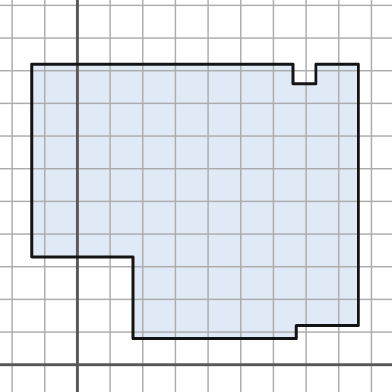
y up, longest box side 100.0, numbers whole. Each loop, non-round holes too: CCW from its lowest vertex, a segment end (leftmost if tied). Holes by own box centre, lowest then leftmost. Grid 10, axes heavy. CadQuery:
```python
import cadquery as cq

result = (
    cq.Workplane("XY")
    .moveTo(17.0, 8.0)
    .lineTo(67.0, 8.0)
    .lineTo(67.0, 12.0)
    .lineTo(86.0, 12.0)
    .lineTo(86.0, 92.0)
    .lineTo(73.0, 92.0)
    .lineTo(73.0, 86.0)
    .lineTo(66.0, 86.0)
    .lineTo(66.0, 92.0)
    .lineTo(-14.0, 92.0)
    .lineTo(-14.0, 33.0)
    .lineTo(17.0, 33.0)
    .close()
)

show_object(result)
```